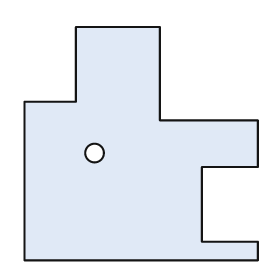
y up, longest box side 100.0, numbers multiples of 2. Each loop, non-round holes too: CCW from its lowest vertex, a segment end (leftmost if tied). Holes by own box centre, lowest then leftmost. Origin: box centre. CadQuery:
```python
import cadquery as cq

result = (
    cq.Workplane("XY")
    .moveTo(-50.0, -50.0)
    .lineTo(50.0, -50.0)
    .lineTo(50.0, -42.0)
    .lineTo(26.0, -42.0)
    .lineTo(26.0, -10.0)
    .lineTo(50.0, -10.0)
    .lineTo(50.0, 10.0)
    .lineTo(8.0, 10.0)
    .lineTo(8.0, 50.0)
    .lineTo(-28.0, 50.0)
    .lineTo(-28.0, 18.0)
    .lineTo(-50.0, 18.0)
    .close()
    .moveTo(-20.0, -4.0)
    .circle(4.0)
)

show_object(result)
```